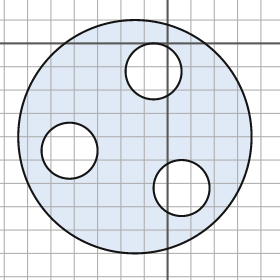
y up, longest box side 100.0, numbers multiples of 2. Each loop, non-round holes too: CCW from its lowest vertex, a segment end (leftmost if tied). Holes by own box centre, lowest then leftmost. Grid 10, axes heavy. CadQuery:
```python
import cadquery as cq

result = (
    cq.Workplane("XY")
    .moveTo(-14.0, -40.0)
    .circle(50.0)
    .moveTo(6.0, -62.0)
    .circle(12.0)
    .moveTo(-42.0, -46.0)
    .circle(12.0)
    .moveTo(-6.0, -12.0)
    .circle(12.0)
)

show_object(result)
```